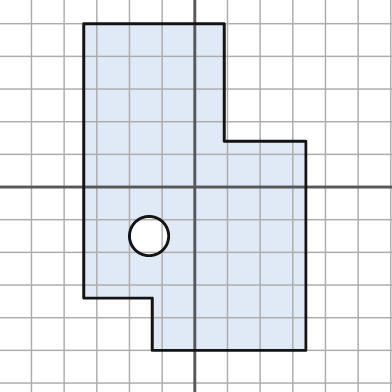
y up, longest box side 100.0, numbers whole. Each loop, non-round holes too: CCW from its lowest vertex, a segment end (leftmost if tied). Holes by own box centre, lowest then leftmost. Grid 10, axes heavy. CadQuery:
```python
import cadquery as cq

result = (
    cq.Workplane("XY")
    .moveTo(-13.0, -50.0)
    .lineTo(34.0, -50.0)
    .lineTo(34.0, 14.0)
    .lineTo(9.0, 14.0)
    .lineTo(9.0, 50.0)
    .lineTo(-34.0, 50.0)
    .lineTo(-34.0, -34.0)
    .lineTo(-13.0, -34.0)
    .close()
    .moveTo(-14.0, -15.0)
    .circle(6.0)
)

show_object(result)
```